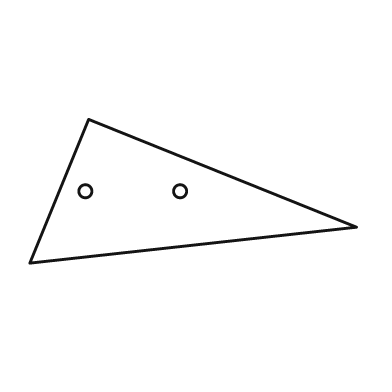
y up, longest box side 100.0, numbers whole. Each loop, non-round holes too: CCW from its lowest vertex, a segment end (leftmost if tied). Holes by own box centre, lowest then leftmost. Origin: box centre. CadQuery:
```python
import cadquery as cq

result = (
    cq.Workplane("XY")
    .moveTo(-50.0, -22.0)
    .lineTo(50.0, -11.0)
    .lineTo(-32.0, 22.0)
    .close()
    .moveTo(-33.0, 0.0)
    .circle(2.0)
    .moveTo(-4.0, 0.0)
    .circle(2.0)
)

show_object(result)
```